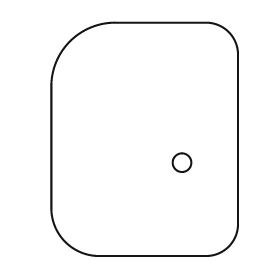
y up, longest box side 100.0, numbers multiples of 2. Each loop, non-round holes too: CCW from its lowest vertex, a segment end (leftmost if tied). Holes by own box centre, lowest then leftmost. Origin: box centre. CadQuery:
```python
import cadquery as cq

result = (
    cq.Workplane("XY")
    .moveTo(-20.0, -50.0)
    .lineTo(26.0, -50.0)
    .threePointArc((36.0, -46.0), (40.0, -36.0))
    .lineTo(40.0, 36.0)
    .threePointArc((36.0, 46.0), (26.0, 50.0))
    .lineTo(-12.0, 50.0)
    .threePointArc((-32.0, 42.0), (-40.0, 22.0))
    .lineTo(-40.0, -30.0)
    .threePointArc((-34.0, -44.0), (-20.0, -50.0))
    .close()
    .moveTo(16.0, -10.0)
    .circle(4.0)
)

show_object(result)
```